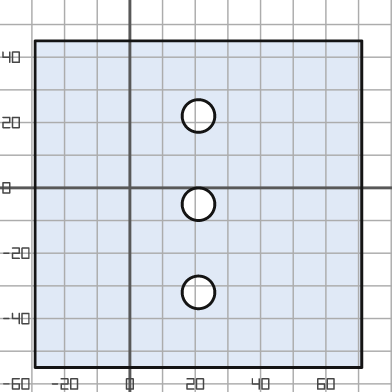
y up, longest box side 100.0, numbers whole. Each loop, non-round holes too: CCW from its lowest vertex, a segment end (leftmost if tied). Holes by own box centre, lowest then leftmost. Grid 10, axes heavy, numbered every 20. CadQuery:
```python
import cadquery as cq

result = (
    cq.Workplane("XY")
    .moveTo(-29.0, -55.0)
    .lineTo(71.0, -55.0)
    .lineTo(71.0, 45.0)
    .lineTo(-29.0, 45.0)
    .close()
    .moveTo(21.0, -32.0)
    .circle(5.0)
    .moveTo(21.0, -5.0)
    .circle(5.0)
    .moveTo(21.0, 22.0)
    .circle(5.0)
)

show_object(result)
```